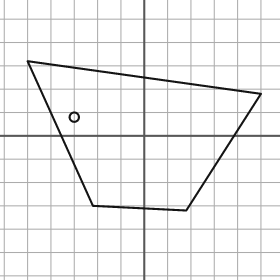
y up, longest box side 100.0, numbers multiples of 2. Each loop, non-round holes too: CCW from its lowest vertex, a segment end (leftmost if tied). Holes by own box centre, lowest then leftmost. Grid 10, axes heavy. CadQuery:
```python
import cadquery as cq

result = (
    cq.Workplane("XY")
    .moveTo(18.0, -32.0)
    .lineTo(50.0, 18.0)
    .lineTo(-50.0, 32.0)
    .lineTo(-22.0, -30.0)
    .close()
    .moveTo(-30.0, 8.0)
    .circle(2.0)
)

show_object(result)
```